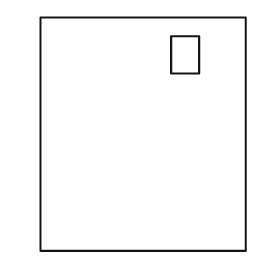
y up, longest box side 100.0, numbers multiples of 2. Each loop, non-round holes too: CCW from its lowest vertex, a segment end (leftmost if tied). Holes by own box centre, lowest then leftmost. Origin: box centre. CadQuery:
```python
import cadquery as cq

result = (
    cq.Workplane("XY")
    .moveTo(-44.0, -50.0)
    .lineTo(44.0, -50.0)
    .lineTo(44.0, 50.0)
    .lineTo(-44.0, 50.0)
    .close()
    .moveTo(12.0, 26.0)
    .lineTo(24.0, 26.0)
    .lineTo(24.0, 42.0)
    .lineTo(12.0, 42.0)
    .close()
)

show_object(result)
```